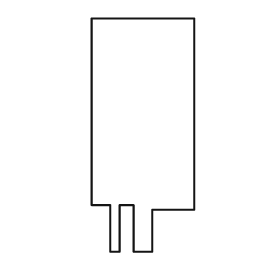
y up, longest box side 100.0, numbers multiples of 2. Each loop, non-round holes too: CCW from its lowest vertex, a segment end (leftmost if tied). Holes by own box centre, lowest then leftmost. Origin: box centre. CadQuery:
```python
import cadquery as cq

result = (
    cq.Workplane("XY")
    .moveTo(-14.0, -50.0)
    .lineTo(-10.0, -50.0)
    .lineTo(-10.0, -30.0)
    .lineTo(-4.0, -30.0)
    .lineTo(-4.0, -50.0)
    .lineTo(4.0, -50.0)
    .lineTo(4.0, -32.0)
    .lineTo(22.0, -32.0)
    .lineTo(22.0, 50.0)
    .lineTo(-22.0, 50.0)
    .lineTo(-22.0, -30.0)
    .lineTo(-14.0, -30.0)
    .close()
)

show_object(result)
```